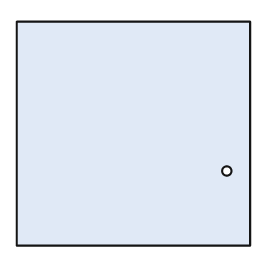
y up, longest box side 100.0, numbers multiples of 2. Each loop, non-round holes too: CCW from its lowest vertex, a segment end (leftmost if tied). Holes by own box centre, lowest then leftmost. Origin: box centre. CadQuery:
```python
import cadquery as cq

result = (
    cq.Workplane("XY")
    .moveTo(-50.0, -48.0)
    .lineTo(50.0, -48.0)
    .lineTo(50.0, 48.0)
    .lineTo(-50.0, 48.0)
    .close()
    .moveTo(40.0, -16.0)
    .circle(2.0)
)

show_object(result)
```